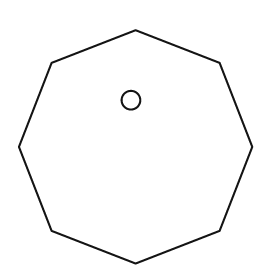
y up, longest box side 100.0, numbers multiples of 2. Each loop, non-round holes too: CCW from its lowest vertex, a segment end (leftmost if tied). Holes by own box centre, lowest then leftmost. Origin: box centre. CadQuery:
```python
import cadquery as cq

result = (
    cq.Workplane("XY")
    .moveTo(0.0, -50.0)
    .lineTo(36.0, -36.0)
    .lineTo(50.0, 0.0)
    .lineTo(36.0, 36.0)
    .lineTo(0.0, 50.0)
    .lineTo(-36.0, 36.0)
    .lineTo(-50.0, 0.0)
    .lineTo(-36.0, -36.0)
    .close()
    .moveTo(-2.0, 20.0)
    .circle(4.0)
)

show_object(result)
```